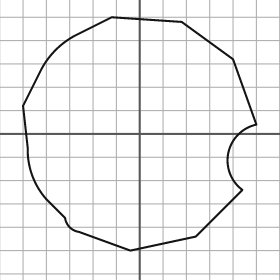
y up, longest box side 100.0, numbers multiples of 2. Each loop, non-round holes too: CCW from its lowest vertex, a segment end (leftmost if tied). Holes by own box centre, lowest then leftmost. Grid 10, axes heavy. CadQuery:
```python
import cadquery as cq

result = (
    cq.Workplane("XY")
    .moveTo(-4.0, -50.0)
    .lineTo(24.0, -44.0)
    .lineTo(44.0, -24.0)
    .threePointArc((38.0, -8.0), (50.0, 4.0))
    .lineTo(40.0, 32.0)
    .lineTo(18.0, 48.0)
    .lineTo(-12.0, 50.0)
    .lineTo(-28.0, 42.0)
    .threePointArc((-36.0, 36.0), (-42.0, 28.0))
    .lineTo(-50.0, 12.0)
    .lineTo(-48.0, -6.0)
    .threePointArc((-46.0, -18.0), (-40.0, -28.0))
    .lineTo(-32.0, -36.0)
    .threePointArc((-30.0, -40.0), (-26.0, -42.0))
    .close()
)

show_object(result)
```